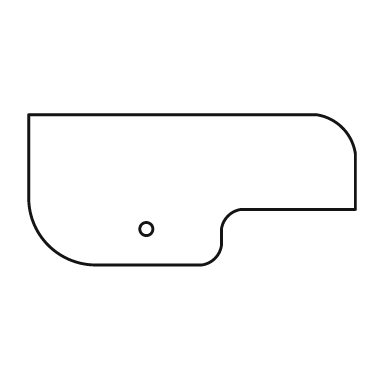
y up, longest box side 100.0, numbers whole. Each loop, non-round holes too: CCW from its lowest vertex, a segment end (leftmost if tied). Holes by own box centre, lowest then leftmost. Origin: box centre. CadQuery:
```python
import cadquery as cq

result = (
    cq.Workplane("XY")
    .moveTo(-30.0, -23.0)
    .lineTo(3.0, -23.0)
    .threePointArc((7.0, -21.0), (9.0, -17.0))
    .lineTo(9.0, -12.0)
    .threePointArc((11.0, -8.0), (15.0, -6.0))
    .lineTo(50.0, -6.0)
    .lineTo(50.0, 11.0)
    .threePointArc((46.0, 19.0), (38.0, 23.0))
    .lineTo(-50.0, 23.0)
    .lineTo(-50.0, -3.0)
    .threePointArc((-44.0, -17.0), (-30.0, -23.0))
    .close()
    .moveTo(-14.0, -12.0)
    .circle(2.0)
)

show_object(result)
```